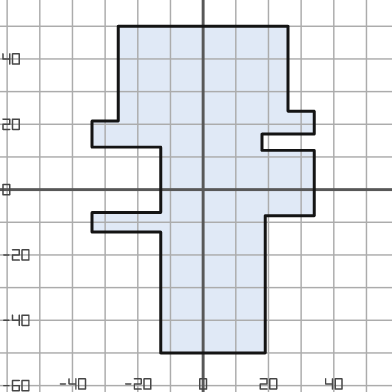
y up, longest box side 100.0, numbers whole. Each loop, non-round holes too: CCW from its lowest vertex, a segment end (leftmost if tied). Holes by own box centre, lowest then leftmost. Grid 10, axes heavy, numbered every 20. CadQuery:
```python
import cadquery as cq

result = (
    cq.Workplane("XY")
    .moveTo(-13.0, -50.0)
    .lineTo(19.0, -50.0)
    .lineTo(19.0, -8.0)
    .lineTo(34.0, -8.0)
    .lineTo(34.0, 12.0)
    .lineTo(18.0, 12.0)
    .lineTo(18.0, 17.0)
    .lineTo(34.0, 17.0)
    .lineTo(34.0, 24.0)
    .lineTo(26.0, 24.0)
    .lineTo(26.0, 50.0)
    .lineTo(-26.0, 50.0)
    .lineTo(-26.0, 21.0)
    .lineTo(-34.0, 21.0)
    .lineTo(-34.0, 13.0)
    .lineTo(-13.0, 13.0)
    .lineTo(-13.0, -7.0)
    .lineTo(-34.0, -7.0)
    .lineTo(-34.0, -13.0)
    .lineTo(-13.0, -13.0)
    .close()
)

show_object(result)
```